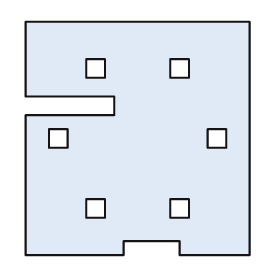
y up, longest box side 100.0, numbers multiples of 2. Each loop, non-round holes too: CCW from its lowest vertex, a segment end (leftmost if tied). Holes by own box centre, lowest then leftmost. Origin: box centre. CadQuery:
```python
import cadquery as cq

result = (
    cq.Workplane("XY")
    .moveTo(-48.0, -50.0)
    .lineTo(-6.0, -50.0)
    .lineTo(-6.0, -44.0)
    .lineTo(18.0, -44.0)
    .lineTo(18.0, -50.0)
    .lineTo(48.0, -50.0)
    .lineTo(48.0, 50.0)
    .lineTo(-48.0, 50.0)
    .lineTo(-48.0, 18.0)
    .lineTo(-10.0, 18.0)
    .lineTo(-10.0, 10.0)
    .lineTo(-48.0, 10.0)
    .close()
    .moveTo(-22.0, -34.0)
    .lineTo(-14.0, -34.0)
    .lineTo(-14.0, -26.0)
    .lineTo(-22.0, -26.0)
    .close()
    .moveTo(14.0, -34.0)
    .lineTo(22.0, -34.0)
    .lineTo(22.0, -26.0)
    .lineTo(14.0, -26.0)
    .close()
    .moveTo(-38.0, -4.0)
    .lineTo(-30.0, -4.0)
    .lineTo(-30.0, 4.0)
    .lineTo(-38.0, 4.0)
    .close()
    .moveTo(30.0, -4.0)
    .lineTo(38.0, -4.0)
    .lineTo(38.0, 4.0)
    .lineTo(30.0, 4.0)
    .close()
    .moveTo(-22.0, 26.0)
    .lineTo(-14.0, 26.0)
    .lineTo(-14.0, 34.0)
    .lineTo(-22.0, 34.0)
    .close()
    .moveTo(14.0, 26.0)
    .lineTo(22.0, 26.0)
    .lineTo(22.0, 34.0)
    .lineTo(14.0, 34.0)
    .close()
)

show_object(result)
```